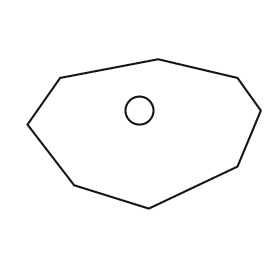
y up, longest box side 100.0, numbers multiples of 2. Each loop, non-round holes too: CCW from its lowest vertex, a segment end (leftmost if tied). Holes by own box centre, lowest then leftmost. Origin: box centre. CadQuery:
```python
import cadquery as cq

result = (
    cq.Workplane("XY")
    .moveTo(2.0, -32.0)
    .lineTo(40.0, -14.0)
    .lineTo(50.0, 10.0)
    .lineTo(40.0, 24.0)
    .lineTo(6.0, 32.0)
    .lineTo(-36.0, 24.0)
    .lineTo(-50.0, 4.0)
    .lineTo(-30.0, -22.0)
    .close()
    .moveTo(-2.0, 10.0)
    .circle(6.0)
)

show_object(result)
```